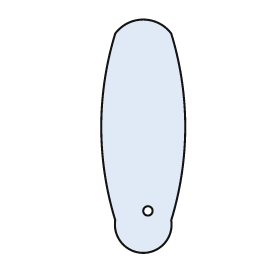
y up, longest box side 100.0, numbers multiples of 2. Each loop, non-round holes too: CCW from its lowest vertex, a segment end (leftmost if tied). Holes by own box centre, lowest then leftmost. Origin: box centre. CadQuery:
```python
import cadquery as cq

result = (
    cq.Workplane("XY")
    .moveTo(-12.0, -36.0)
    .threePointArc((0.0, -50.0), (12.0, -36.0))
    .threePointArc((18.0, 4.0), (12.0, 44.0))
    .threePointArc((0.0, 50.0), (-12.0, 44.0))
    .threePointArc((-18.0, 4.0), (-12.0, -36.0))
    .close()
    .moveTo(2.0, -32.0)
    .circle(2.0)
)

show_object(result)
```